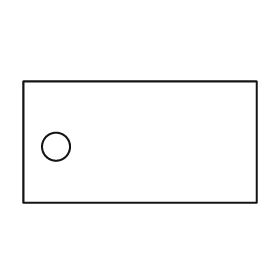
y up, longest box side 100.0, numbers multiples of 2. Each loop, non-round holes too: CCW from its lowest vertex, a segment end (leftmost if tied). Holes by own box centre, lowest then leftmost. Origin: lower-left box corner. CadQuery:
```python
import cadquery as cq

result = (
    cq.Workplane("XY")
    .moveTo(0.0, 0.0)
    .lineTo(100.0, 0.0)
    .lineTo(100.0, 52.0)
    .lineTo(0.0, 52.0)
    .close()
    .moveTo(14.0, 24.0)
    .circle(6.0)
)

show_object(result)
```